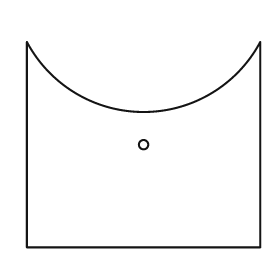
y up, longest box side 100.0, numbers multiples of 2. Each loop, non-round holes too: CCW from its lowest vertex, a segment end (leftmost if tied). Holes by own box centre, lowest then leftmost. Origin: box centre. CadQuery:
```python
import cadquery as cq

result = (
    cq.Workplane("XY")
    .moveTo(-50.0, -44.0)
    .lineTo(50.0, -44.0)
    .lineTo(50.0, 44.0)
    .threePointArc((0.0, 14.0), (-50.0, 44.0))
    .close()
    .moveTo(0.0, 0.0)
    .circle(2.0)
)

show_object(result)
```